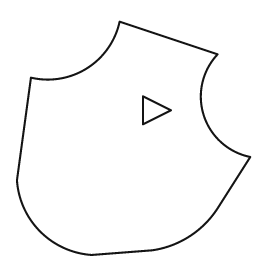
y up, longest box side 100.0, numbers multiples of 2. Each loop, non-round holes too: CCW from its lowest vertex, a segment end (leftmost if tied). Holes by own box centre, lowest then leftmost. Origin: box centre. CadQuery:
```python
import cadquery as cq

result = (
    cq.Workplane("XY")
    .moveTo(-18.0, -50.0)
    .lineTo(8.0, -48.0)
    .threePointArc((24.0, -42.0), (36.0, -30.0))
    .lineTo(50.0, -8.0)
    .threePointArc((30.0, 10.0), (36.0, 36.0))
    .lineTo(-6.0, 50.0)
    .threePointArc((-20.0, 30.0), (-44.0, 26.0))
    .lineTo(-50.0, -18.0)
    .threePointArc((-40.0, -40.0), (-18.0, -50.0))
    .close()
    .moveTo(4.0, 6.0)
    .lineTo(16.0, 12.0)
    .lineTo(4.0, 18.0)
    .close()
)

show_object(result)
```